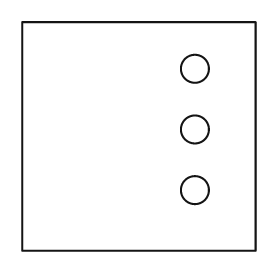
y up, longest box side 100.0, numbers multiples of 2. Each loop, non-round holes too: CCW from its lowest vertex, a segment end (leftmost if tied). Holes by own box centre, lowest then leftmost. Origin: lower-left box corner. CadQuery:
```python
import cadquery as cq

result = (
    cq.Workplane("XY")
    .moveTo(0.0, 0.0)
    .lineTo(100.0, 0.0)
    .lineTo(100.0, 98.0)
    .lineTo(0.0, 98.0)
    .close()
    .moveTo(74.0, 26.0)
    .circle(6.0)
    .moveTo(74.0, 52.0)
    .circle(6.0)
    .moveTo(74.0, 78.0)
    .circle(6.0)
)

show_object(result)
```